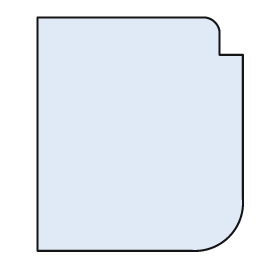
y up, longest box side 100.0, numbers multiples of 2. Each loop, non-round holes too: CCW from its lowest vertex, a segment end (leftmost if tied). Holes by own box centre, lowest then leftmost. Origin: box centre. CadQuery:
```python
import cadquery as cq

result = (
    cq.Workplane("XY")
    .moveTo(-44.0, -50.0)
    .lineTo(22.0, -50.0)
    .threePointArc((38.0, -44.0), (44.0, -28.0))
    .lineTo(44.0, 34.0)
    .lineTo(34.0, 34.0)
    .lineTo(34.0, 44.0)
    .threePointArc((32.0, 48.0), (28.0, 50.0))
    .lineTo(-44.0, 50.0)
    .close()
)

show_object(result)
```